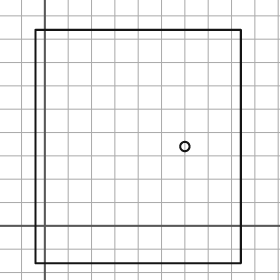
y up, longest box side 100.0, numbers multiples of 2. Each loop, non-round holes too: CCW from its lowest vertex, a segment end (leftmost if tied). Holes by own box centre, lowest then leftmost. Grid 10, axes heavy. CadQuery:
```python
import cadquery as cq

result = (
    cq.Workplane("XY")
    .moveTo(-4.0, -16.0)
    .lineTo(84.0, -16.0)
    .lineTo(84.0, 84.0)
    .lineTo(-4.0, 84.0)
    .close()
    .moveTo(60.0, 34.0)
    .circle(2.0)
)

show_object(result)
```